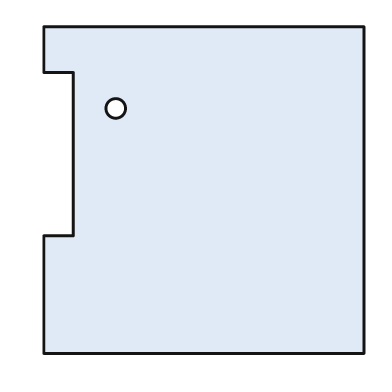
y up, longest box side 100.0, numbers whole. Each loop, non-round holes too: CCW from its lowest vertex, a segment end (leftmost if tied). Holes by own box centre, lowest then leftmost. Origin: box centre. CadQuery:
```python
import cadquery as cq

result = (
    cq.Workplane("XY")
    .moveTo(-49.0, -50.0)
    .lineTo(49.0, -50.0)
    .lineTo(49.0, 50.0)
    .lineTo(-49.0, 50.0)
    .lineTo(-49.0, 36.0)
    .lineTo(-40.0, 36.0)
    .lineTo(-40.0, -14.0)
    .lineTo(-49.0, -14.0)
    .close()
    .moveTo(-27.0, 25.0)
    .circle(3.0)
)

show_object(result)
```